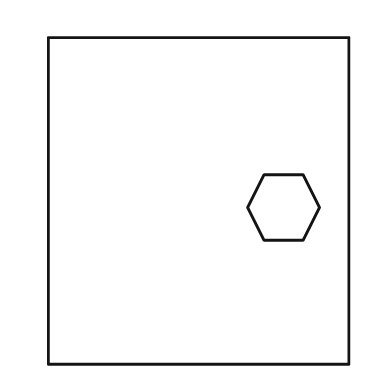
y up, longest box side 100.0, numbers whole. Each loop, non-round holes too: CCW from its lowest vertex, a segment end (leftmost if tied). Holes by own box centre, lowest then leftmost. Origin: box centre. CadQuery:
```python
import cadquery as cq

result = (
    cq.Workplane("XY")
    .moveTo(-46.0, -50.0)
    .lineTo(46.0, -50.0)
    .lineTo(46.0, 50.0)
    .lineTo(-46.0, 50.0)
    .close()
    .moveTo(20.0, -12.0)
    .lineTo(32.0, -12.0)
    .lineTo(37.0, -2.0)
    .lineTo(32.0, 8.0)
    .lineTo(20.0, 8.0)
    .lineTo(15.0, -2.0)
    .close()
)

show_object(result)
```